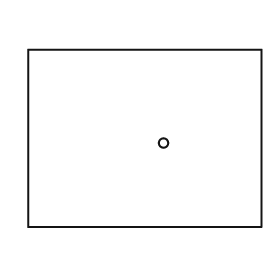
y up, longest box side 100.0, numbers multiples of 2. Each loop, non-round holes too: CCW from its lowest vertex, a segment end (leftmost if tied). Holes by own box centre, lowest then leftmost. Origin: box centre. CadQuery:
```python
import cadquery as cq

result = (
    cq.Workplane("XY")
    .moveTo(-50.0, -38.0)
    .lineTo(50.0, -38.0)
    .lineTo(50.0, 38.0)
    .lineTo(-50.0, 38.0)
    .close()
    .moveTo(8.0, -2.0)
    .circle(2.0)
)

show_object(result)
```